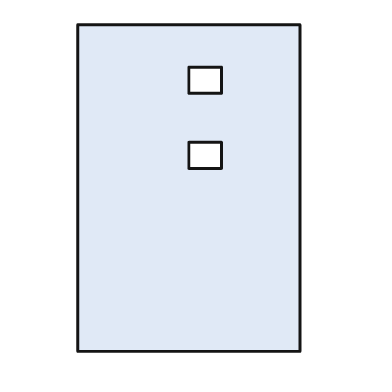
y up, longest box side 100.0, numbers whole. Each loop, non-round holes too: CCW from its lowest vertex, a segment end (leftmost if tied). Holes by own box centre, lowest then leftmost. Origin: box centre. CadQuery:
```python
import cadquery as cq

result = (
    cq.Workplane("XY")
    .moveTo(-34.0, -50.0)
    .lineTo(34.0, -50.0)
    .lineTo(34.0, 50.0)
    .lineTo(-34.0, 50.0)
    .close()
    .moveTo(0.0, 6.0)
    .lineTo(10.0, 6.0)
    .lineTo(10.0, 14.0)
    .lineTo(0.0, 14.0)
    .close()
    .moveTo(0.0, 29.0)
    .lineTo(10.0, 29.0)
    .lineTo(10.0, 37.0)
    .lineTo(0.0, 37.0)
    .close()
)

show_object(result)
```